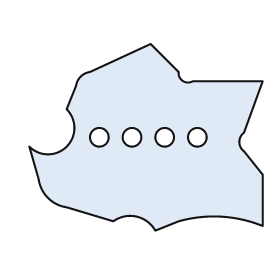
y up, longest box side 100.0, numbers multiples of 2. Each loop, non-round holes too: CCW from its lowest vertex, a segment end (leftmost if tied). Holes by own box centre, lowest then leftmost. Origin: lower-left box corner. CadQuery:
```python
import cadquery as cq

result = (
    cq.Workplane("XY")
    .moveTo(54.0, 0.0)
    .lineTo(64.0, 4.0)
    .threePointArc((82.0, 6.0), (100.0, 2.0))
    .lineTo(100.0, 24.0)
    .lineTo(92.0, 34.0)
    .threePointArc((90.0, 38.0), (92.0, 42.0))
    .lineTo(100.0, 64.0)
    .lineTo(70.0, 64.0)
    .threePointArc((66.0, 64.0), (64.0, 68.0))
    .lineTo(52.0, 80.0)
    .lineTo(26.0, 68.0)
    .threePointArc((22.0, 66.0), (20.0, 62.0))
    .lineTo(16.0, 52.0)
    .threePointArc((16.0, 36.0), (0.0, 36.0))
    .lineTo(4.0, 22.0)
    .threePointArc((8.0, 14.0), (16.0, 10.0))
    .lineTo(36.0, 4.0)
    .threePointArc((46.0, 6.0), (54.0, 0.0))
    .close()
    .moveTo(30.0, 40.0)
    .circle(4.0)
    .moveTo(44.0, 40.0)
    .circle(4.0)
    .moveTo(58.0, 40.0)
    .circle(4.0)
    .moveTo(72.0, 40.0)
    .circle(4.0)
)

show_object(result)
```